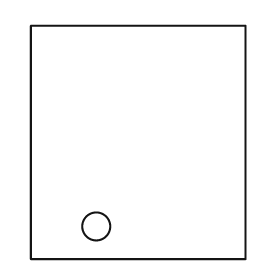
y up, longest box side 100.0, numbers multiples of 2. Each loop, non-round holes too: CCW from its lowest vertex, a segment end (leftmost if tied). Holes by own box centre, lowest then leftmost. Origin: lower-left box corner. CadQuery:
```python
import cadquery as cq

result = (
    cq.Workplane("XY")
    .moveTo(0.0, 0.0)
    .lineTo(92.0, 0.0)
    .lineTo(92.0, 100.0)
    .lineTo(0.0, 100.0)
    .close()
    .moveTo(28.0, 14.0)
    .circle(6.0)
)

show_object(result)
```